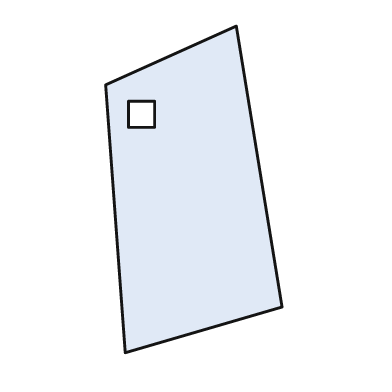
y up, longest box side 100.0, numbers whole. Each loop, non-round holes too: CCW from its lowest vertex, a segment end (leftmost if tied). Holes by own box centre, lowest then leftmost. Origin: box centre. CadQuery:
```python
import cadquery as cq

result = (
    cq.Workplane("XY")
    .moveTo(-21.0, -50.0)
    .lineTo(27.0, -36.0)
    .lineTo(13.0, 50.0)
    .lineTo(-27.0, 32.0)
    .close()
    .moveTo(-20.0, 19.0)
    .lineTo(-12.0, 19.0)
    .lineTo(-12.0, 27.0)
    .lineTo(-20.0, 27.0)
    .close()
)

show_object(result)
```